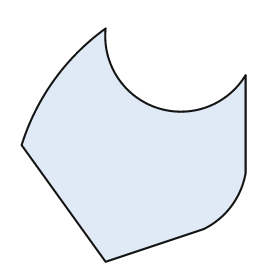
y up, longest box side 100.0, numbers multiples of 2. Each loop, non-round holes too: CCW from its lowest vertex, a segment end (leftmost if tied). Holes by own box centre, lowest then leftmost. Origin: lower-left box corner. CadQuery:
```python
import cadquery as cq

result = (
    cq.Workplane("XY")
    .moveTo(36.0, 0.0)
    .lineTo(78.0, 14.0)
    .threePointArc((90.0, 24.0), (96.0, 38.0))
    .lineTo(96.0, 80.0)
    .threePointArc((58.0, 66.0), (36.0, 100.0))
    .threePointArc((14.0, 78.0), (0.0, 50.0))
    .close()
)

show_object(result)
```